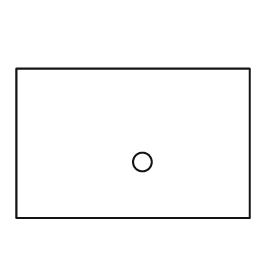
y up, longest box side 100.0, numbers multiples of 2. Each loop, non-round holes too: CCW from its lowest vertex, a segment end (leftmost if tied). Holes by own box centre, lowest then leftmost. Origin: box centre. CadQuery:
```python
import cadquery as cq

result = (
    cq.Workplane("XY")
    .moveTo(-50.0, -32.0)
    .lineTo(50.0, -32.0)
    .lineTo(50.0, 32.0)
    .lineTo(-50.0, 32.0)
    .close()
    .moveTo(4.0, -8.0)
    .circle(4.0)
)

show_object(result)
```